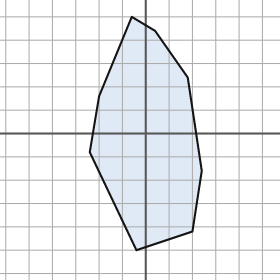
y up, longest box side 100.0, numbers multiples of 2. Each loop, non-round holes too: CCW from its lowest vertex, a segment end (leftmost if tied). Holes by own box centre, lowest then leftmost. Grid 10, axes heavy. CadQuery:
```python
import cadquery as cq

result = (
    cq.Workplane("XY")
    .moveTo(-4.0, -50.0)
    .lineTo(20.0, -42.0)
    .lineTo(24.0, -16.0)
    .lineTo(18.0, 24.0)
    .lineTo(4.0, 44.0)
    .lineTo(-6.0, 50.0)
    .lineTo(-20.0, 16.0)
    .lineTo(-24.0, -8.0)
    .close()
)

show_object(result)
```